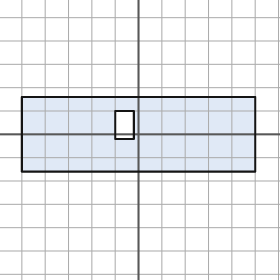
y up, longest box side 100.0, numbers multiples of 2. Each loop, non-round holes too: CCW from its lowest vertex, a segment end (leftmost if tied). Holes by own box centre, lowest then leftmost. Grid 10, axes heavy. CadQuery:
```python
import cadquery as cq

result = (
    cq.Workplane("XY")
    .moveTo(-50.0, -16.0)
    .lineTo(50.0, -16.0)
    .lineTo(50.0, 16.0)
    .lineTo(-50.0, 16.0)
    .close()
    .moveTo(-10.0, -2.0)
    .lineTo(-2.0, -2.0)
    .lineTo(-2.0, 10.0)
    .lineTo(-10.0, 10.0)
    .close()
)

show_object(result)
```